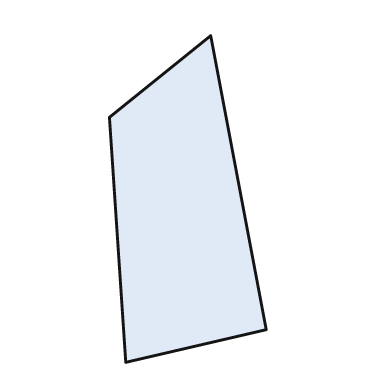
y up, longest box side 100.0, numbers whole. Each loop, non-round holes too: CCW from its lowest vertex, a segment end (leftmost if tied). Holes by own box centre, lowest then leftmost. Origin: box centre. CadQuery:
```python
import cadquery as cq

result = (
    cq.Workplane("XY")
    .moveTo(-19.0, -50.0)
    .lineTo(24.0, -40.0)
    .lineTo(7.0, 50.0)
    .lineTo(-24.0, 25.0)
    .close()
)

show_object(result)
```